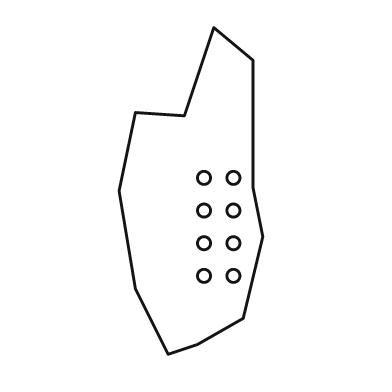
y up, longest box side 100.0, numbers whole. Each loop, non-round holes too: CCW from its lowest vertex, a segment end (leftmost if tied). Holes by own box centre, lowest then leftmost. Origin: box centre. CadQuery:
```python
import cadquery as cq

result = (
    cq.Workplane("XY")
    .moveTo(-7.0, -50.0)
    .lineTo(2.0, -47.0)
    .lineTo(16.0, -39.0)
    .lineTo(22.0, -14.0)
    .lineTo(19.0, 1.0)
    .lineTo(19.0, 40.0)
    .lineTo(7.0, 50.0)
    .lineTo(-2.0, 23.0)
    .lineTo(-17.0, 24.0)
    .lineTo(-22.0, 0.0)
    .lineTo(-17.0, -30.0)
    .close()
    .moveTo(4.0, -26.0)
    .circle(2.0)
    .moveTo(13.0, -26.0)
    .circle(2.0)
    .moveTo(4.0, -16.0)
    .circle(2.0)
    .moveTo(13.0, -16.0)
    .circle(2.0)
    .moveTo(4.0, -6.0)
    .circle(2.0)
    .moveTo(13.0, -6.0)
    .circle(2.0)
    .moveTo(4.0, 4.0)
    .circle(2.0)
    .moveTo(13.0, 4.0)
    .circle(2.0)
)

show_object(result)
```